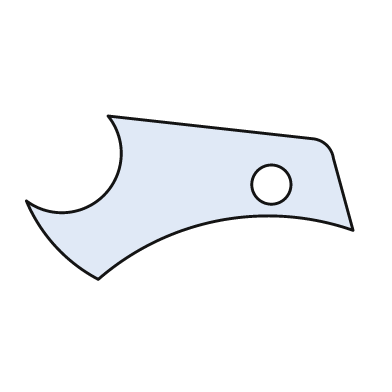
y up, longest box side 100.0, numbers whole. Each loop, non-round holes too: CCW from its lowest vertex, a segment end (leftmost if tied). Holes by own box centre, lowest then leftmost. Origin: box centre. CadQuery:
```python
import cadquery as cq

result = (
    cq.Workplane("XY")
    .moveTo(-28.0, -25.0)
    .threePointArc((9.0, -7.0), (50.0, -10.0))
    .lineTo(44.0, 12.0)
    .threePointArc((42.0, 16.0), (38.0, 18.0))
    .lineTo(-25.0, 25.0)
    .threePointArc((-26.0, 1.0), (-50.0, -1.0))
    .threePointArc((-41.0, -15.0), (-28.0, -25.0))
    .close()
    .moveTo(25.0, 4.0)
    .circle(6.0)
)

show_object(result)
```